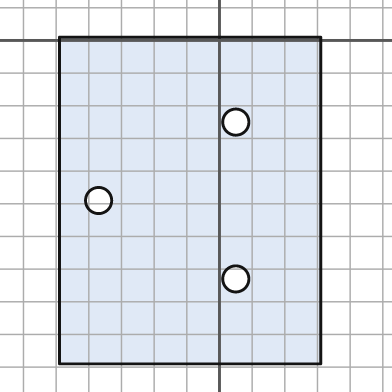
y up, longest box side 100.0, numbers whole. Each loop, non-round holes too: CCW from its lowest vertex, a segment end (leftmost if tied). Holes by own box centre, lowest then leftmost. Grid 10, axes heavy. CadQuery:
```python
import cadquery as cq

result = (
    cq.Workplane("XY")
    .moveTo(-49.0, -99.0)
    .lineTo(31.0, -99.0)
    .lineTo(31.0, 1.0)
    .lineTo(-49.0, 1.0)
    .close()
    .moveTo(5.0, -73.0)
    .circle(4.0)
    .moveTo(-37.0, -49.0)
    .circle(4.0)
    .moveTo(5.0, -25.0)
    .circle(4.0)
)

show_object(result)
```